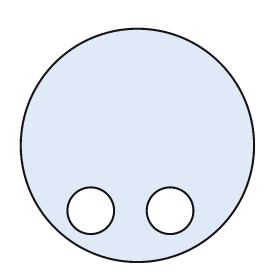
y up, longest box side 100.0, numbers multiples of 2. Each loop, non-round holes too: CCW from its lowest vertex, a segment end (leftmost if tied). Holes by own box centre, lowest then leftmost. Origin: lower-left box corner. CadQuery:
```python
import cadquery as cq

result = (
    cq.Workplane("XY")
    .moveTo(50.0, 50.0)
    .circle(50.0)
    .moveTo(30.0, 22.0)
    .circle(10.0)
    .moveTo(64.0, 22.0)
    .circle(10.0)
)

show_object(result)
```